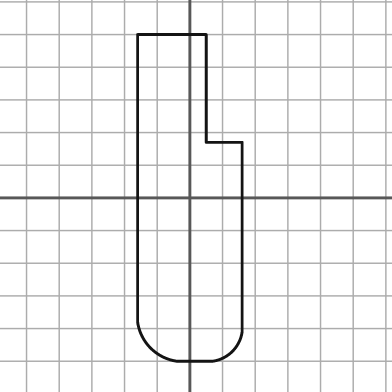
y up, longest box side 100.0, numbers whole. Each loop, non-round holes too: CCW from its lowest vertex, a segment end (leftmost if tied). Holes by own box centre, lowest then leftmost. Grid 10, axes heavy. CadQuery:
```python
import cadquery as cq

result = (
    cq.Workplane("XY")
    .moveTo(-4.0, -50.0)
    .lineTo(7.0, -50.0)
    .threePointArc((13.0, -47.0), (16.0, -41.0))
    .lineTo(16.0, 17.0)
    .lineTo(5.0, 17.0)
    .lineTo(5.0, 50.0)
    .lineTo(-16.0, 50.0)
    .lineTo(-16.0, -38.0)
    .threePointArc((-12.0, -46.0), (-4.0, -50.0))
    .close()
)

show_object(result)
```